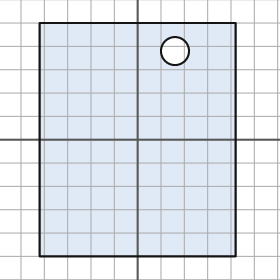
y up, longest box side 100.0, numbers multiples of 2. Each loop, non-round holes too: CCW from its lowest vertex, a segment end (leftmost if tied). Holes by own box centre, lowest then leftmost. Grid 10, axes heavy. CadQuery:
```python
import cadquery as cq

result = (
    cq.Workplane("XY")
    .moveTo(-42.0, -50.0)
    .lineTo(42.0, -50.0)
    .lineTo(42.0, 50.0)
    .lineTo(-42.0, 50.0)
    .close()
    .moveTo(16.0, 38.0)
    .circle(6.0)
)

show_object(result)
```